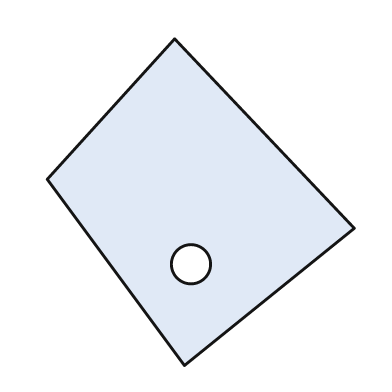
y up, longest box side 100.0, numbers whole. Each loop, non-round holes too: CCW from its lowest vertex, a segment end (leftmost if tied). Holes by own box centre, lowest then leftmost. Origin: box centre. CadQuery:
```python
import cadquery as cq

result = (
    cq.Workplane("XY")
    .moveTo(-5.0, -50.0)
    .lineTo(47.0, -8.0)
    .lineTo(-8.0, 50.0)
    .lineTo(-47.0, 7.0)
    .close()
    .moveTo(-3.0, -19.0)
    .circle(6.0)
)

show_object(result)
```